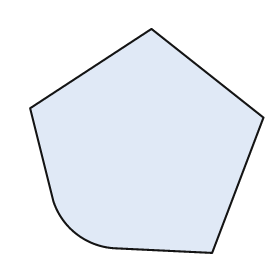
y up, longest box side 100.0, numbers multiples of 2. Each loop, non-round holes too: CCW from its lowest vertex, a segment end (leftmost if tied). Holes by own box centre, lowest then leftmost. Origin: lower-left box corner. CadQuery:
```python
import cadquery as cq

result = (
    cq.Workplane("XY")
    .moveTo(78.0, 0.0)
    .lineTo(100.0, 58.0)
    .lineTo(52.0, 96.0)
    .lineTo(0.0, 62.0)
    .lineTo(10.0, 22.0)
    .threePointArc((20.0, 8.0), (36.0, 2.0))
    .close()
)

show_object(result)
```